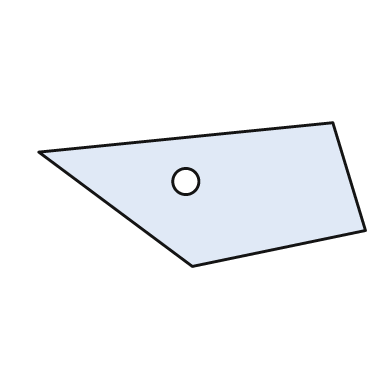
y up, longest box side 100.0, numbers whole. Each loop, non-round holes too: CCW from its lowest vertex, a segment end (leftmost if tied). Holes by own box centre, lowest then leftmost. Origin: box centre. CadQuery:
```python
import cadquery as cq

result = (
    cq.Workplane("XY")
    .moveTo(-3.0, -22.0)
    .lineTo(50.0, -11.0)
    .lineTo(40.0, 22.0)
    .lineTo(-50.0, 13.0)
    .close()
    .moveTo(-5.0, 4.0)
    .circle(4.0)
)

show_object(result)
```